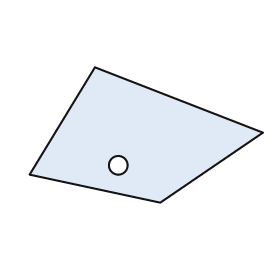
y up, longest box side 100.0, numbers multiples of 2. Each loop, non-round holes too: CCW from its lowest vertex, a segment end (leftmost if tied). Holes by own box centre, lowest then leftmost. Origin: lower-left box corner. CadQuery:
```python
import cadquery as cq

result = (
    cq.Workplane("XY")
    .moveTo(56.0, 0.0)
    .lineTo(100.0, 30.0)
    .lineTo(28.0, 58.0)
    .lineTo(0.0, 12.0)
    .close()
    .moveTo(38.0, 16.0)
    .circle(4.0)
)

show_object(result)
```